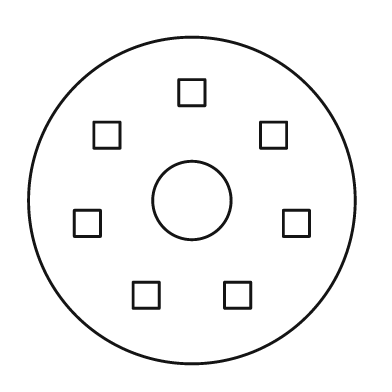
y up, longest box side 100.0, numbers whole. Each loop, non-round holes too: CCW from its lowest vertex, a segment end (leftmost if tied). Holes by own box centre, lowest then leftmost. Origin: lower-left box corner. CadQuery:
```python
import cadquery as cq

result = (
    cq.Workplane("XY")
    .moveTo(50.0, 50.0)
    .circle(50.0)
    .moveTo(32.0, 17.0)
    .lineTo(40.0, 17.0)
    .lineTo(40.0, 25.0)
    .lineTo(32.0, 25.0)
    .close()
    .moveTo(60.0, 17.0)
    .lineTo(68.0, 17.0)
    .lineTo(68.0, 25.0)
    .lineTo(60.0, 25.0)
    .close()
    .moveTo(14.0, 39.0)
    .lineTo(22.0, 39.0)
    .lineTo(22.0, 47.0)
    .lineTo(14.0, 47.0)
    .close()
    .moveTo(78.0, 39.0)
    .lineTo(86.0, 39.0)
    .lineTo(86.0, 47.0)
    .lineTo(78.0, 47.0)
    .close()
    .moveTo(50.0, 50.0)
    .circle(12.0)
    .moveTo(20.0, 66.0)
    .lineTo(28.0, 66.0)
    .lineTo(28.0, 74.0)
    .lineTo(20.0, 74.0)
    .close()
    .moveTo(71.0, 66.0)
    .lineTo(79.0, 66.0)
    .lineTo(79.0, 74.0)
    .lineTo(71.0, 74.0)
    .close()
    .moveTo(46.0, 79.0)
    .lineTo(54.0, 79.0)
    .lineTo(54.0, 87.0)
    .lineTo(46.0, 87.0)
    .close()
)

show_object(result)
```